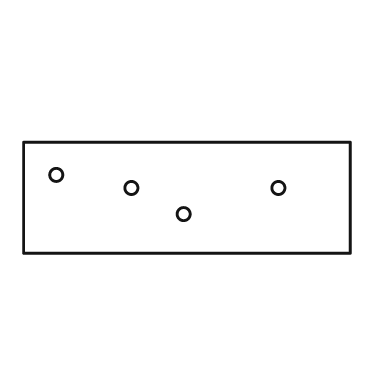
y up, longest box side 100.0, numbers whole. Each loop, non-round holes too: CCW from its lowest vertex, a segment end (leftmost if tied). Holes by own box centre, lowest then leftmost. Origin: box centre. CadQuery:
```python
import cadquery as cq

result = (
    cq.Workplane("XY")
    .moveTo(-50.0, -17.0)
    .lineTo(50.0, -17.0)
    .lineTo(50.0, 17.0)
    .lineTo(-50.0, 17.0)
    .close()
    .moveTo(-1.0, -5.0)
    .circle(2.0)
    .moveTo(-17.0, 3.0)
    .circle(2.0)
    .moveTo(28.0, 3.0)
    .circle(2.0)
    .moveTo(-40.0, 7.0)
    .circle(2.0)
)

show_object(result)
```